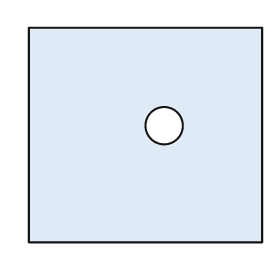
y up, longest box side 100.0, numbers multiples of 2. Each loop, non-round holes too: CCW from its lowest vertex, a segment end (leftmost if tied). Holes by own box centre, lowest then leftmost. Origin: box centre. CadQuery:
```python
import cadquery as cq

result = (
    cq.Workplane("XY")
    .moveTo(-50.0, -46.0)
    .lineTo(50.0, -46.0)
    .lineTo(50.0, 46.0)
    .lineTo(-50.0, 46.0)
    .close()
    .moveTo(8.0, 4.0)
    .circle(8.0)
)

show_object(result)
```